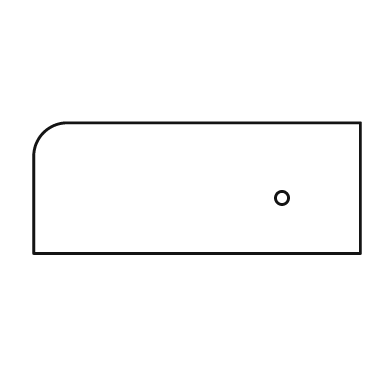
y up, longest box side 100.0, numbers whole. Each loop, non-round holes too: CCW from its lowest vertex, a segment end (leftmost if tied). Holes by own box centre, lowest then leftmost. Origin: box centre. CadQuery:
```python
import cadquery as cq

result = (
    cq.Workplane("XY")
    .moveTo(-50.0, -20.0)
    .lineTo(50.0, -20.0)
    .lineTo(50.0, 20.0)
    .lineTo(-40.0, 20.0)
    .threePointArc((-47.0, 17.0), (-50.0, 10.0))
    .close()
    .moveTo(26.0, -3.0)
    .circle(2.0)
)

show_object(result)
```